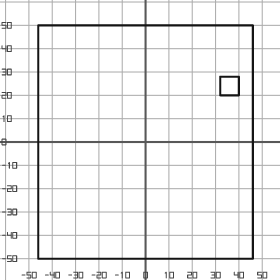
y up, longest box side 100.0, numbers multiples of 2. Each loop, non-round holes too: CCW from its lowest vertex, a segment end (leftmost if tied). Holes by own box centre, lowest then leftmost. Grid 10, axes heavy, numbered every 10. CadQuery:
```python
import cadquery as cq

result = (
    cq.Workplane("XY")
    .moveTo(-46.0, -50.0)
    .lineTo(46.0, -50.0)
    .lineTo(46.0, 50.0)
    .lineTo(-46.0, 50.0)
    .close()
    .moveTo(32.0, 20.0)
    .lineTo(40.0, 20.0)
    .lineTo(40.0, 28.0)
    .lineTo(32.0, 28.0)
    .close()
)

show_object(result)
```